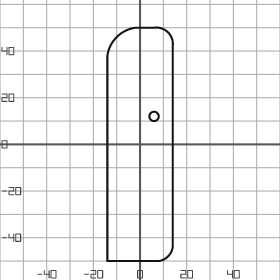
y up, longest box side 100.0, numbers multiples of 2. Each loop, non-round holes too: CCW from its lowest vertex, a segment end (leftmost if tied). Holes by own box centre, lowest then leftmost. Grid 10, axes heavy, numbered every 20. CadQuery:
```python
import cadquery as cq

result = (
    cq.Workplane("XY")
    .moveTo(-14.0, -50.0)
    .lineTo(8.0, -50.0)
    .threePointArc((12.0, -48.0), (14.0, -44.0))
    .lineTo(14.0, 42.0)
    .threePointArc((12.0, 48.0), (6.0, 50.0))
    .lineTo(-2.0, 50.0)
    .threePointArc((-10.0, 46.0), (-14.0, 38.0))
    .close()
    .moveTo(6.0, 12.0)
    .circle(2.0)
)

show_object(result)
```